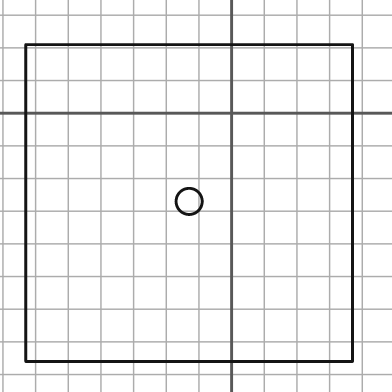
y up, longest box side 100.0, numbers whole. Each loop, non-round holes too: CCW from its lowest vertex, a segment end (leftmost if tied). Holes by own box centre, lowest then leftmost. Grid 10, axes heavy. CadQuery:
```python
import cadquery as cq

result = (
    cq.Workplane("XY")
    .moveTo(-63.0, -76.0)
    .lineTo(37.0, -76.0)
    .lineTo(37.0, 21.0)
    .lineTo(-63.0, 21.0)
    .close()
    .moveTo(-13.0, -27.0)
    .circle(4.0)
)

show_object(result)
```